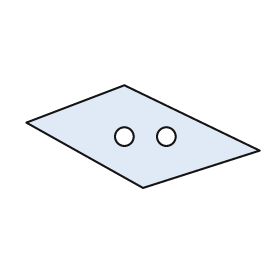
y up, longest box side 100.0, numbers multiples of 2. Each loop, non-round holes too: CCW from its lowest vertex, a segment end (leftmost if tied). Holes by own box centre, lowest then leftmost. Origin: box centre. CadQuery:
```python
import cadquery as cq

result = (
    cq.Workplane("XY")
    .moveTo(0.0, -22.0)
    .lineTo(50.0, -6.0)
    .lineTo(-8.0, 22.0)
    .lineTo(-50.0, 6.0)
    .close()
    .moveTo(-8.0, 0.0)
    .circle(4.0)
    .moveTo(10.0, 0.0)
    .circle(4.0)
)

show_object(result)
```